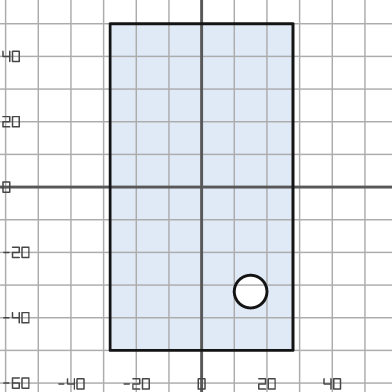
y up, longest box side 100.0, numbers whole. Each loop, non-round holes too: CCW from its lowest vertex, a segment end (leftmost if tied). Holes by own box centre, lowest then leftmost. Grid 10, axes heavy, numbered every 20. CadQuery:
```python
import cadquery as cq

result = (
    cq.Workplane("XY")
    .moveTo(-28.0, -50.0)
    .lineTo(28.0, -50.0)
    .lineTo(28.0, 50.0)
    .lineTo(-28.0, 50.0)
    .close()
    .moveTo(15.0, -32.0)
    .circle(5.0)
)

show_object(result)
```